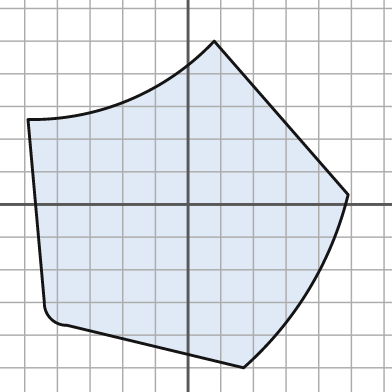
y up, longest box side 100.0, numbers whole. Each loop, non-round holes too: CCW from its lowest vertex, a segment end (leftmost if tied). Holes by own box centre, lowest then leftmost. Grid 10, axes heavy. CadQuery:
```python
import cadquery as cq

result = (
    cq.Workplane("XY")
    .moveTo(17.0, -50.0)
    .threePointArc((37.0, -26.0), (49.0, 3.0))
    .lineTo(8.0, 50.0)
    .threePointArc((-18.0, 32.0), (-49.0, 26.0))
    .lineTo(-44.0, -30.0)
    .threePointArc((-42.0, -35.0), (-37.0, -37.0))
    .close()
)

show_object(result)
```